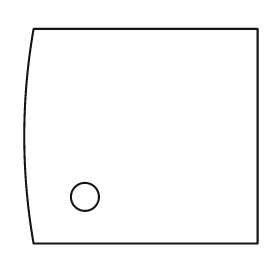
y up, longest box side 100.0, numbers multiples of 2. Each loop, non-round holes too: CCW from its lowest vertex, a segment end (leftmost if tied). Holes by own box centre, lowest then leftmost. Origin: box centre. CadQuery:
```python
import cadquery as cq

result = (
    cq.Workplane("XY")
    .moveTo(-46.0, -46.0)
    .lineTo(50.0, -46.0)
    .lineTo(50.0, 46.0)
    .lineTo(-46.0, 46.0)
    .threePointArc((-50.0, 0.0), (-46.0, -46.0))
    .close()
    .moveTo(-24.0, -26.0)
    .circle(6.0)
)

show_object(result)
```